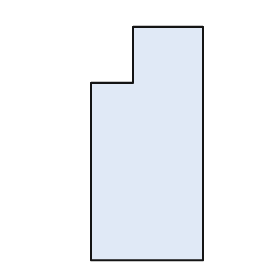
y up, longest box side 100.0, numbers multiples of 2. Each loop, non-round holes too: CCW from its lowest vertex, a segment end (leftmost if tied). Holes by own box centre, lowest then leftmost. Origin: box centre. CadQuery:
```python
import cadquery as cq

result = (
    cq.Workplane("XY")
    .moveTo(-24.0, -50.0)
    .lineTo(24.0, -50.0)
    .lineTo(24.0, 50.0)
    .lineTo(-6.0, 50.0)
    .lineTo(-6.0, 26.0)
    .lineTo(-24.0, 26.0)
    .close()
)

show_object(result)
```